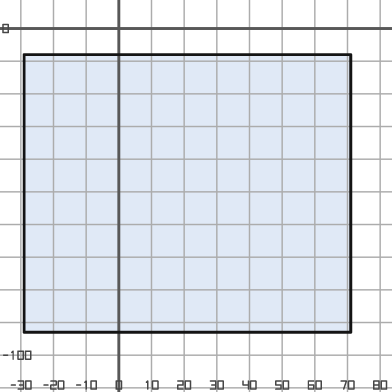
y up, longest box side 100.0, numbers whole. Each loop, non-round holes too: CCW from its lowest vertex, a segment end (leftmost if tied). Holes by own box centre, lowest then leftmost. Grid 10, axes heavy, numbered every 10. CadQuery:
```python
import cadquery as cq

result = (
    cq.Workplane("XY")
    .moveTo(-29.0, -93.0)
    .lineTo(71.0, -93.0)
    .lineTo(71.0, -8.0)
    .lineTo(-29.0, -8.0)
    .close()
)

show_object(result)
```